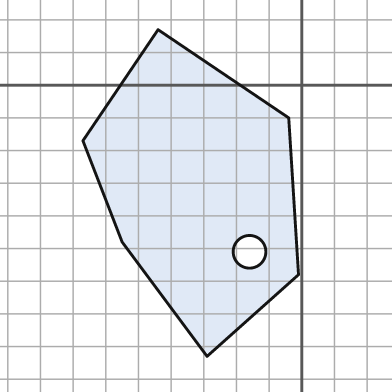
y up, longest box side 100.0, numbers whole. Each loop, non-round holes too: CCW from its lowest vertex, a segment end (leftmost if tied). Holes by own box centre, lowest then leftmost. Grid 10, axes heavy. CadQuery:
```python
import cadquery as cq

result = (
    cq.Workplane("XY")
    .moveTo(-29.0, -83.0)
    .lineTo(-1.0, -58.0)
    .lineTo(-4.0, -10.0)
    .lineTo(-44.0, 17.0)
    .lineTo(-67.0, -17.0)
    .lineTo(-55.0, -48.0)
    .close()
    .moveTo(-16.0, -51.0)
    .circle(5.0)
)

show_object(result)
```